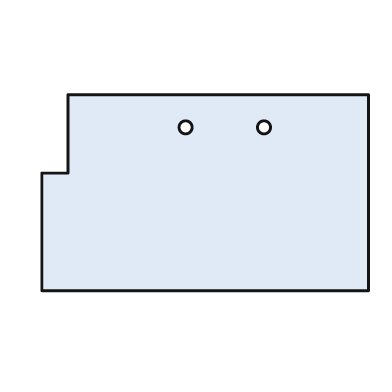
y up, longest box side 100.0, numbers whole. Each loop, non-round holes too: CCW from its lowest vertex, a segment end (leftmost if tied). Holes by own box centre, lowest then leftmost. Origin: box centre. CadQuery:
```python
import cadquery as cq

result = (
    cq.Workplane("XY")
    .moveTo(-50.0, -30.0)
    .lineTo(50.0, -30.0)
    .lineTo(50.0, 30.0)
    .lineTo(-42.0, 30.0)
    .lineTo(-42.0, 6.0)
    .lineTo(-50.0, 6.0)
    .close()
    .moveTo(-6.0, 20.0)
    .circle(2.0)
    .moveTo(18.0, 20.0)
    .circle(2.0)
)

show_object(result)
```